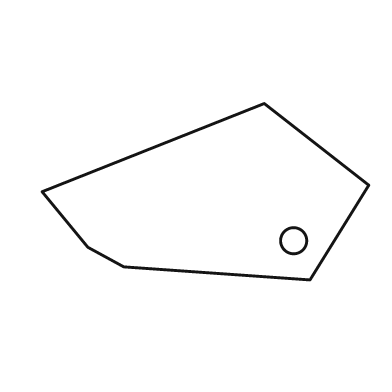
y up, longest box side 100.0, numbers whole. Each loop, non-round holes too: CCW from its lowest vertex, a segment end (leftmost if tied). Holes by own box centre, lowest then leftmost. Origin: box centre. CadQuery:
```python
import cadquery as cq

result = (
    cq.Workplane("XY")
    .moveTo(32.0, -27.0)
    .lineTo(50.0, 2.0)
    .lineTo(18.0, 27.0)
    .lineTo(-50.0, 0.0)
    .lineTo(-36.0, -17.0)
    .lineTo(-25.0, -23.0)
    .close()
    .moveTo(27.0, -15.0)
    .circle(4.0)
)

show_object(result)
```